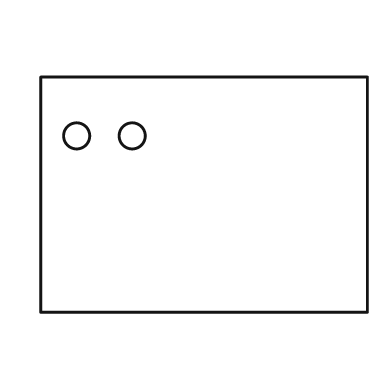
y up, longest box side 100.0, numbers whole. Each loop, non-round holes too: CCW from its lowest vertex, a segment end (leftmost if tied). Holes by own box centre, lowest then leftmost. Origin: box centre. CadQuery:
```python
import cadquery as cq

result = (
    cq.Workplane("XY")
    .moveTo(-50.0, -36.0)
    .lineTo(50.0, -36.0)
    .lineTo(50.0, 36.0)
    .lineTo(-50.0, 36.0)
    .close()
    .moveTo(-39.0, 18.0)
    .circle(4.0)
    .moveTo(-22.0, 18.0)
    .circle(4.0)
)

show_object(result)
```